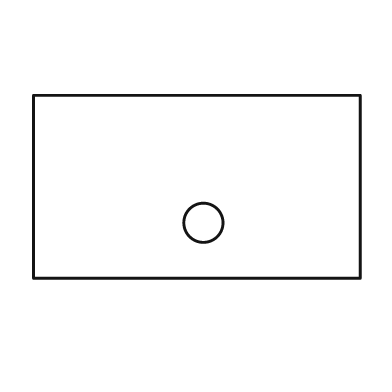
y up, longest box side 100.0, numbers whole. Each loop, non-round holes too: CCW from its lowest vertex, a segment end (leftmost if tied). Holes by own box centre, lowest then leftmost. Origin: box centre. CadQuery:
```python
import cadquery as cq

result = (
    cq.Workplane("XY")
    .moveTo(-50.0, -28.0)
    .lineTo(50.0, -28.0)
    .lineTo(50.0, 28.0)
    .lineTo(-50.0, 28.0)
    .close()
    .moveTo(2.0, -11.0)
    .circle(6.0)
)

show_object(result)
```